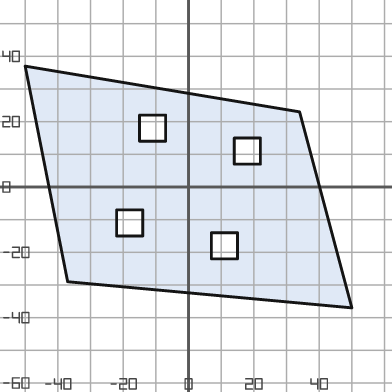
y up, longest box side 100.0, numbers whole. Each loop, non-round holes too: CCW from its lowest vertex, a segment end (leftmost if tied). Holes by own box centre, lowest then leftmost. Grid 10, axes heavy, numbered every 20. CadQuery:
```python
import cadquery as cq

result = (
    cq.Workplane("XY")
    .moveTo(50.0, -37.0)
    .lineTo(34.0, 23.0)
    .lineTo(-50.0, 37.0)
    .lineTo(-37.0, -29.0)
    .close()
    .moveTo(7.0, -22.0)
    .lineTo(15.0, -22.0)
    .lineTo(15.0, -14.0)
    .lineTo(7.0, -14.0)
    .close()
    .moveTo(-22.0, -15.0)
    .lineTo(-14.0, -15.0)
    .lineTo(-14.0, -7.0)
    .lineTo(-22.0, -7.0)
    .close()
    .moveTo(14.0, 7.0)
    .lineTo(22.0, 7.0)
    .lineTo(22.0, 15.0)
    .lineTo(14.0, 15.0)
    .close()
    .moveTo(-15.0, 14.0)
    .lineTo(-7.0, 14.0)
    .lineTo(-7.0, 22.0)
    .lineTo(-15.0, 22.0)
    .close()
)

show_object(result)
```